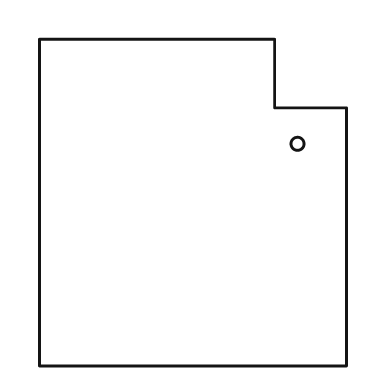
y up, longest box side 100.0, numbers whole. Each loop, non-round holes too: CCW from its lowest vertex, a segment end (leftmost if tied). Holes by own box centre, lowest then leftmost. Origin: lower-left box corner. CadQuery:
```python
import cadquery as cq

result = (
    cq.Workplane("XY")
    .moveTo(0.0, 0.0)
    .lineTo(94.0, 0.0)
    .lineTo(94.0, 79.0)
    .lineTo(72.0, 79.0)
    .lineTo(72.0, 100.0)
    .lineTo(0.0, 100.0)
    .close()
    .moveTo(79.0, 68.0)
    .circle(2.0)
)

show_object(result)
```